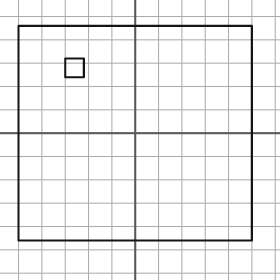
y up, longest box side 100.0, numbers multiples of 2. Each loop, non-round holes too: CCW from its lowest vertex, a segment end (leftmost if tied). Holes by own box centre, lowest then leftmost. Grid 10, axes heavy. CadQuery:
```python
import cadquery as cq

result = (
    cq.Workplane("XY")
    .moveTo(-50.0, -46.0)
    .lineTo(50.0, -46.0)
    .lineTo(50.0, 46.0)
    .lineTo(-50.0, 46.0)
    .close()
    .moveTo(-30.0, 24.0)
    .lineTo(-22.0, 24.0)
    .lineTo(-22.0, 32.0)
    .lineTo(-30.0, 32.0)
    .close()
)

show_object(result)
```